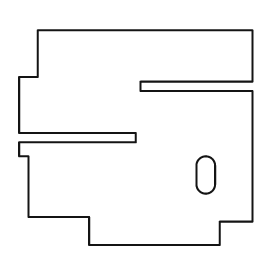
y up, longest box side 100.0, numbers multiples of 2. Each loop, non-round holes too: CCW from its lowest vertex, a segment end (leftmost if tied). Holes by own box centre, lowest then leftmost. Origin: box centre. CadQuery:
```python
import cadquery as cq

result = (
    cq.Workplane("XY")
    .moveTo(-20.0, -46.0)
    .lineTo(36.0, -46.0)
    .lineTo(36.0, -36.0)
    .lineTo(50.0, -36.0)
    .lineTo(50.0, 20.0)
    .lineTo(2.0, 20.0)
    .lineTo(2.0, 24.0)
    .lineTo(50.0, 24.0)
    .lineTo(50.0, 46.0)
    .lineTo(-42.0, 46.0)
    .lineTo(-42.0, 26.0)
    .lineTo(-50.0, 26.0)
    .lineTo(-50.0, 2.0)
    .lineTo(0.0, 2.0)
    .lineTo(0.0, -2.0)
    .lineTo(-50.0, -2.0)
    .lineTo(-50.0, -8.0)
    .lineTo(-46.0, -8.0)
    .lineTo(-46.0, -34.0)
    .lineTo(-20.0, -34.0)
    .close()
    .moveTo(26.0, -20.0)
    .threePointArc((30.0, -24.0), (34.0, -20.0))
    .lineTo(34.0, -12.0)
    .threePointArc((30.0, -8.0), (26.0, -12.0))
    .close()
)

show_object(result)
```